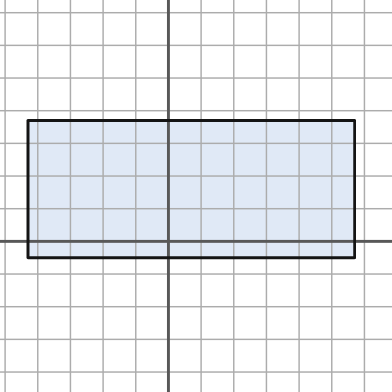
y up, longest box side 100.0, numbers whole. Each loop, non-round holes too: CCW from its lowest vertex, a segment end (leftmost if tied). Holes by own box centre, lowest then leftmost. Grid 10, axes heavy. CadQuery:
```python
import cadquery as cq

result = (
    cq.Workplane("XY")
    .moveTo(-43.0, -5.0)
    .lineTo(57.0, -5.0)
    .lineTo(57.0, 37.0)
    .lineTo(-43.0, 37.0)
    .close()
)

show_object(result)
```